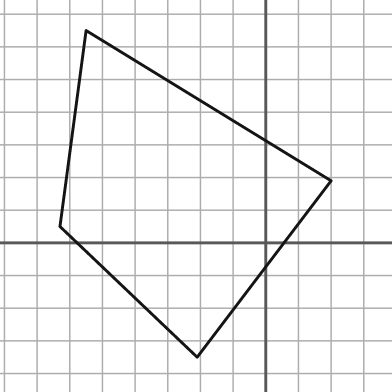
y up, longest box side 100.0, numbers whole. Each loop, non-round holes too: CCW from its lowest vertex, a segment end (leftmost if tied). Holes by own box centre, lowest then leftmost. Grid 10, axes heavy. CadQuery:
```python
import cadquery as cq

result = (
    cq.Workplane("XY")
    .moveTo(-21.0, -35.0)
    .lineTo(20.0, 19.0)
    .lineTo(-55.0, 65.0)
    .lineTo(-63.0, 5.0)
    .close()
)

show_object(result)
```